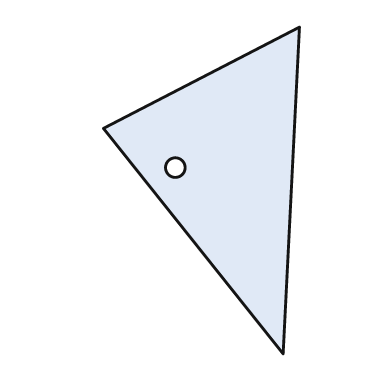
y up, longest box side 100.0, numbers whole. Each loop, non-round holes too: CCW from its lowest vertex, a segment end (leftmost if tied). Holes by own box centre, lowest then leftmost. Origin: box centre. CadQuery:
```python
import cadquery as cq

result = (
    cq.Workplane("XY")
    .moveTo(25.0, -50.0)
    .lineTo(30.0, 50.0)
    .lineTo(-30.0, 19.0)
    .close()
    .moveTo(-8.0, 7.0)
    .circle(3.0)
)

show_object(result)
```